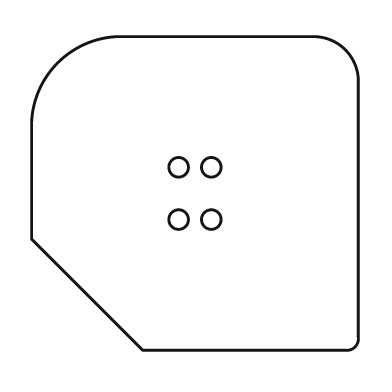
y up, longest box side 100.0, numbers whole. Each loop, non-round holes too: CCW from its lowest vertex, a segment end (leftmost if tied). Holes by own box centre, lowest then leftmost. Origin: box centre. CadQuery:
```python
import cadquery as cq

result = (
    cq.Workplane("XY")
    .moveTo(-16.0, -48.0)
    .lineTo(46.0, -48.0)
    .threePointArc((49.0, -47.0), (50.0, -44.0))
    .lineTo(50.0, 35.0)
    .threePointArc((46.0, 44.0), (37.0, 48.0))
    .lineTo(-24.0, 48.0)
    .threePointArc((-42.0, 40.0), (-50.0, 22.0))
    .lineTo(-50.0, -14.0)
    .close()
    .moveTo(-5.0, -8.0)
    .circle(3.0)
    .moveTo(5.0, -8.0)
    .circle(3.0)
    .moveTo(-5.0, 8.0)
    .circle(3.0)
    .moveTo(5.0, 8.0)
    .circle(3.0)
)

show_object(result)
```